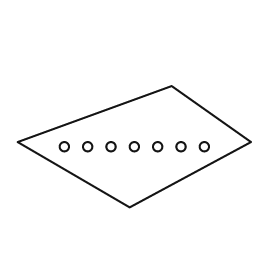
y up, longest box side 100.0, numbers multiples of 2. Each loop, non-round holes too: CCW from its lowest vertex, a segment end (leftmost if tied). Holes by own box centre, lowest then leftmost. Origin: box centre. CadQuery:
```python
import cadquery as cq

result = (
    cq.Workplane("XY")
    .moveTo(-2.0, -26.0)
    .lineTo(50.0, 2.0)
    .lineTo(16.0, 26.0)
    .lineTo(-50.0, 2.0)
    .close()
    .moveTo(-30.0, 0.0)
    .circle(2.0)
    .moveTo(-20.0, 0.0)
    .circle(2.0)
    .moveTo(-10.0, 0.0)
    .circle(2.0)
    .moveTo(0.0, 0.0)
    .circle(2.0)
    .moveTo(10.0, 0.0)
    .circle(2.0)
    .moveTo(20.0, 0.0)
    .circle(2.0)
    .moveTo(30.0, 0.0)
    .circle(2.0)
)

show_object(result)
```